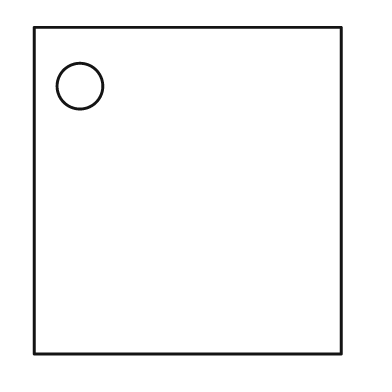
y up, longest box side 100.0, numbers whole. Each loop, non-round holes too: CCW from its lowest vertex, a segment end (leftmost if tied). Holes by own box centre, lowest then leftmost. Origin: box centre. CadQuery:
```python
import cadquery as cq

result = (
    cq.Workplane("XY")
    .moveTo(-47.0, -50.0)
    .lineTo(47.0, -50.0)
    .lineTo(47.0, 50.0)
    .lineTo(-47.0, 50.0)
    .close()
    .moveTo(-33.0, 32.0)
    .circle(7.0)
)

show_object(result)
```